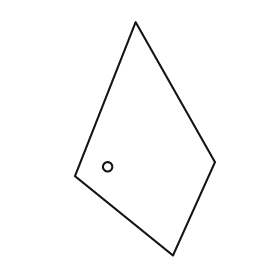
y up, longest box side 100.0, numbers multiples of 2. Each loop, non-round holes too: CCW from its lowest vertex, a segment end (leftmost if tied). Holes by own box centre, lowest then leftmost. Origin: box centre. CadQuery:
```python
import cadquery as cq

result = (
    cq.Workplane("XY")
    .moveTo(12.0, -50.0)
    .lineTo(30.0, -10.0)
    .lineTo(-4.0, 50.0)
    .lineTo(-30.0, -16.0)
    .close()
    .moveTo(-16.0, -12.0)
    .circle(2.0)
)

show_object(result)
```